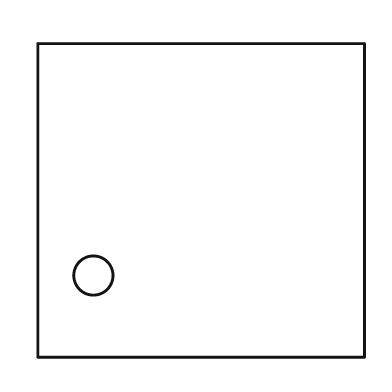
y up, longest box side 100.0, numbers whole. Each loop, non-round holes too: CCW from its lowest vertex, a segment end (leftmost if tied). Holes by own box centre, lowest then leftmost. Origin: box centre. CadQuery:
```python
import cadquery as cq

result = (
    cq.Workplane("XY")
    .moveTo(-50.0, -48.0)
    .lineTo(50.0, -48.0)
    .lineTo(50.0, 48.0)
    .lineTo(-50.0, 48.0)
    .close()
    .moveTo(-33.0, -23.0)
    .circle(6.0)
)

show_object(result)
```